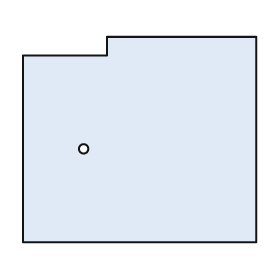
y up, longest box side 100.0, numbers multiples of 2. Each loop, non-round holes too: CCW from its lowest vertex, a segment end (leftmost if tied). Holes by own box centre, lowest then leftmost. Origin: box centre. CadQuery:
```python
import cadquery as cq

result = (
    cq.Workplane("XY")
    .moveTo(-50.0, -44.0)
    .lineTo(50.0, -44.0)
    .lineTo(50.0, 44.0)
    .lineTo(-14.0, 44.0)
    .lineTo(-14.0, 36.0)
    .lineTo(-50.0, 36.0)
    .close()
    .moveTo(-24.0, -4.0)
    .circle(2.0)
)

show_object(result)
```